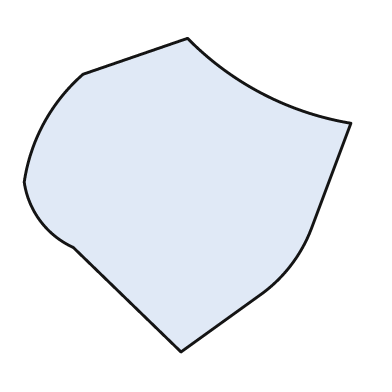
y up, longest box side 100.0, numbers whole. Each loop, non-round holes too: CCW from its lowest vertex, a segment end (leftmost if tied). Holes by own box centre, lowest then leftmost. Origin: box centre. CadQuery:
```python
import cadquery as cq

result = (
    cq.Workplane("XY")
    .moveTo(-2.0, -48.0)
    .lineTo(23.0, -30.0)
    .threePointArc((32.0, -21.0), (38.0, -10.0))
    .lineTo(50.0, 22.0)
    .threePointArc((23.0, 31.0), (0.0, 48.0))
    .lineTo(-32.0, 37.0)
    .threePointArc((-44.0, 22.0), (-50.0, 4.0))
    .threePointArc((-45.0, -8.0), (-35.0, -16.0))
    .close()
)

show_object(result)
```